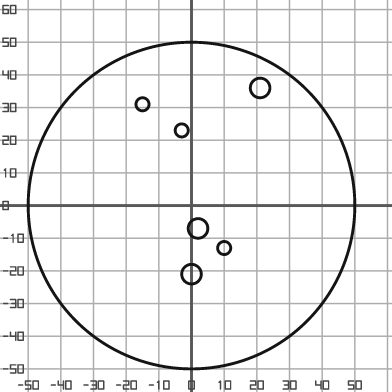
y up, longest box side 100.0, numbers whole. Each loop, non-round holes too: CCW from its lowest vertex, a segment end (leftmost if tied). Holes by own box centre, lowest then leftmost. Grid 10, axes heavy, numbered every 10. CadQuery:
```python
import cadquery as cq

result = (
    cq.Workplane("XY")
    .moveTo(0.0, 0.0)
    .circle(50.0)
    .moveTo(0.0, -21.0)
    .circle(3.0)
    .moveTo(10.0, -13.0)
    .circle(2.0)
    .moveTo(2.0, -7.0)
    .circle(3.0)
    .moveTo(-3.0, 23.0)
    .circle(2.0)
    .moveTo(-15.0, 31.0)
    .circle(2.0)
    .moveTo(21.0, 36.0)
    .circle(3.0)
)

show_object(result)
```